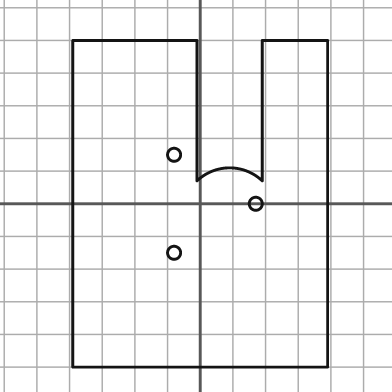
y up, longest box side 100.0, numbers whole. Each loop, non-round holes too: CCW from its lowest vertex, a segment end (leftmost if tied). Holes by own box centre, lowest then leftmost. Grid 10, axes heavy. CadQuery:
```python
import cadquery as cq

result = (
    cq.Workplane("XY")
    .moveTo(-39.0, -50.0)
    .lineTo(39.0, -50.0)
    .lineTo(39.0, 50.0)
    .lineTo(19.0, 50.0)
    .lineTo(19.0, 7.0)
    .threePointArc((9.0, 11.0), (-1.0, 7.0))
    .lineTo(-1.0, 50.0)
    .lineTo(-39.0, 50.0)
    .close()
    .moveTo(-8.0, -15.0)
    .circle(2.0)
    .moveTo(17.0, 0.0)
    .circle(2.0)
    .moveTo(-8.0, 15.0)
    .circle(2.0)
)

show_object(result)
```